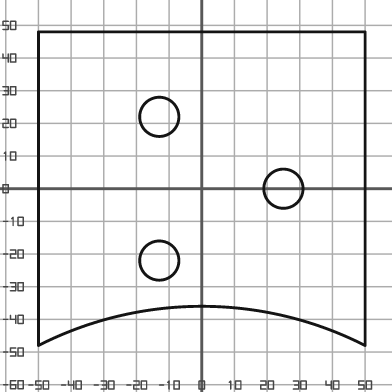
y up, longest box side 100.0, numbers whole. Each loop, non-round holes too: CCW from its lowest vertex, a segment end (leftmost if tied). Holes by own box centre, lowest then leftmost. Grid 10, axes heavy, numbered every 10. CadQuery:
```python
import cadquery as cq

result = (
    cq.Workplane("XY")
    .moveTo(-50.0, -48.0)
    .threePointArc((0.0, -36.0), (50.0, -48.0))
    .lineTo(50.0, 48.0)
    .lineTo(-50.0, 48.0)
    .close()
    .moveTo(-13.0, -22.0)
    .circle(6.0)
    .moveTo(25.0, 0.0)
    .circle(6.0)
    .moveTo(-13.0, 22.0)
    .circle(6.0)
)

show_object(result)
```